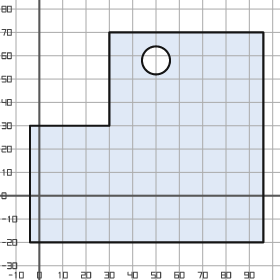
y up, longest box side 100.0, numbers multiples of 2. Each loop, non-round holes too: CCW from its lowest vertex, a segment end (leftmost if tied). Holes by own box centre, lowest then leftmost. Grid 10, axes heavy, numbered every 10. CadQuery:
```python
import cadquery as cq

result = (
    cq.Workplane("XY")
    .moveTo(-4.0, -20.0)
    .lineTo(96.0, -20.0)
    .lineTo(96.0, 70.0)
    .lineTo(30.0, 70.0)
    .lineTo(30.0, 30.0)
    .lineTo(-4.0, 30.0)
    .close()
    .moveTo(50.0, 58.0)
    .circle(6.0)
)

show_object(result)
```